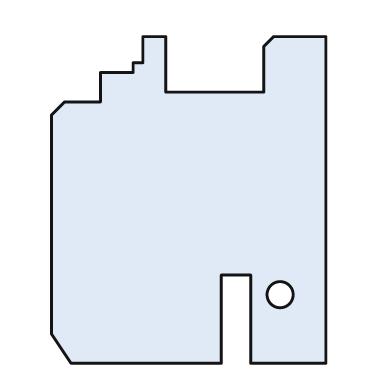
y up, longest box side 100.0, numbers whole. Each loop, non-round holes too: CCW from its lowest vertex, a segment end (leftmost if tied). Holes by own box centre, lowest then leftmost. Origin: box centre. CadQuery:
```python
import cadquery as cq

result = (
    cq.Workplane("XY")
    .moveTo(-36.0, -50.0)
    .lineTo(10.0, -50.0)
    .lineTo(10.0, -23.0)
    .lineTo(19.0, -23.0)
    .lineTo(19.0, -50.0)
    .lineTo(42.0, -50.0)
    .lineTo(42.0, 50.0)
    .lineTo(26.0, 50.0)
    .lineTo(23.0, 47.0)
    .lineTo(23.0, 33.0)
    .lineTo(-7.0, 33.0)
    .lineTo(-7.0, 50.0)
    .lineTo(-14.0, 50.0)
    .lineTo(-14.0, 42.0)
    .lineTo(-17.0, 42.0)
    .lineTo(-17.0, 39.0)
    .lineTo(-27.0, 39.0)
    .lineTo(-27.0, 30.0)
    .lineTo(-38.0, 30.0)
    .lineTo(-42.0, 26.0)
    .lineTo(-42.0, -41.0)
    .close()
    .moveTo(28.0, -29.0)
    .circle(4.0)
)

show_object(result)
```